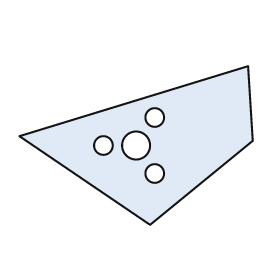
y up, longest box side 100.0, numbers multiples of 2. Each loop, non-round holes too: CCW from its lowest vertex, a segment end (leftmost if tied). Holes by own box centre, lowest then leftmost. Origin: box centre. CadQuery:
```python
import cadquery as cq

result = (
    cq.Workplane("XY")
    .moveTo(6.0, -34.0)
    .lineTo(50.0, 2.0)
    .lineTo(48.0, 34.0)
    .lineTo(-50.0, 4.0)
    .close()
    .moveTo(8.0, -12.0)
    .circle(4.0)
    .moveTo(-14.0, 0.0)
    .circle(4.0)
    .moveTo(0.0, 0.0)
    .circle(6.0)
    .moveTo(8.0, 12.0)
    .circle(4.0)
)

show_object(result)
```